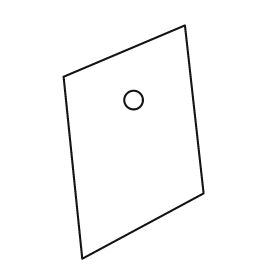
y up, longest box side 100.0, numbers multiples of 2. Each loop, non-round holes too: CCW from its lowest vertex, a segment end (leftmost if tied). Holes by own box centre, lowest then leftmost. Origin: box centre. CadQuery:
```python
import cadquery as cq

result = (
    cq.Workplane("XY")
    .moveTo(-22.0, -50.0)
    .lineTo(30.0, -22.0)
    .lineTo(22.0, 50.0)
    .lineTo(-30.0, 28.0)
    .close()
    .moveTo(0.0, 18.0)
    .circle(4.0)
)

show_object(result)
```